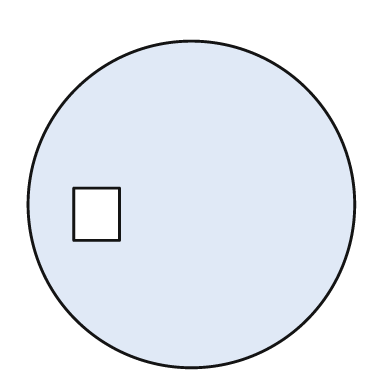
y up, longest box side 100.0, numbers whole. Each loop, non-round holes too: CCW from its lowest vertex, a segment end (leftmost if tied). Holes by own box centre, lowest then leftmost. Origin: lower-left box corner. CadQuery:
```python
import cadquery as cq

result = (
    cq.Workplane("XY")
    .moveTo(50.0, 50.0)
    .circle(50.0)
    .moveTo(14.0, 39.0)
    .lineTo(28.0, 39.0)
    .lineTo(28.0, 55.0)
    .lineTo(14.0, 55.0)
    .close()
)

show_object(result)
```